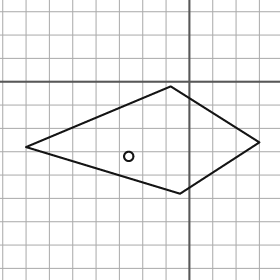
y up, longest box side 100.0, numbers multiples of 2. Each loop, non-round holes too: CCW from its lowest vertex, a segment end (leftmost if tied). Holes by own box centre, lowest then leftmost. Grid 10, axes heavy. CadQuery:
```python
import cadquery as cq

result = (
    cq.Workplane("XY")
    .moveTo(-4.0, -48.0)
    .lineTo(30.0, -26.0)
    .lineTo(-8.0, -2.0)
    .lineTo(-70.0, -28.0)
    .close()
    .moveTo(-26.0, -32.0)
    .circle(2.0)
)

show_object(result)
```